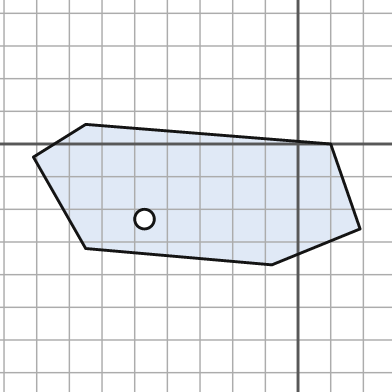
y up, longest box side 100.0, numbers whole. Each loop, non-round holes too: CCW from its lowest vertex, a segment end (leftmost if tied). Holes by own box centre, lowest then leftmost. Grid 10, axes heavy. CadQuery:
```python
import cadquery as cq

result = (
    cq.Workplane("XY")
    .moveTo(-8.0, -37.0)
    .lineTo(19.0, -26.0)
    .lineTo(10.0, 0.0)
    .lineTo(-65.0, 6.0)
    .lineTo(-81.0, -4.0)
    .lineTo(-65.0, -32.0)
    .close()
    .moveTo(-47.0, -23.0)
    .circle(3.0)
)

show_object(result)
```